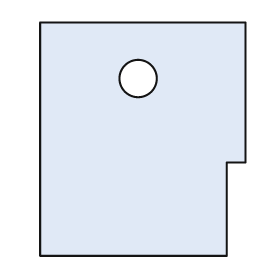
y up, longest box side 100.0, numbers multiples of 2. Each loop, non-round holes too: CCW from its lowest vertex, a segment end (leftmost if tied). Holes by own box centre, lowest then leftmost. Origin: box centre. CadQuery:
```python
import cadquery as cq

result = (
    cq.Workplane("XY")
    .moveTo(-44.0, -50.0)
    .lineTo(36.0, -50.0)
    .lineTo(36.0, -10.0)
    .lineTo(44.0, -10.0)
    .lineTo(44.0, 50.0)
    .lineTo(-44.0, 50.0)
    .close()
    .moveTo(-2.0, 26.0)
    .circle(8.0)
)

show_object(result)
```